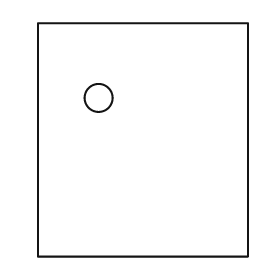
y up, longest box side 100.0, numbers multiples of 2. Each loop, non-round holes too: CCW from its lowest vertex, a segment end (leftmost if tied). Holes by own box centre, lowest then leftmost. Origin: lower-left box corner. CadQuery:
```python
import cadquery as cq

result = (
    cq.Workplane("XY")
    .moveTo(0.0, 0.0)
    .lineTo(90.0, 0.0)
    .lineTo(90.0, 100.0)
    .lineTo(0.0, 100.0)
    .close()
    .moveTo(26.0, 68.0)
    .circle(6.0)
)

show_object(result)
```